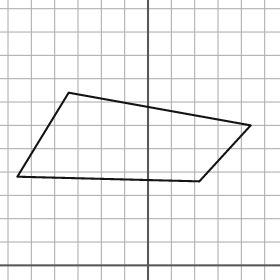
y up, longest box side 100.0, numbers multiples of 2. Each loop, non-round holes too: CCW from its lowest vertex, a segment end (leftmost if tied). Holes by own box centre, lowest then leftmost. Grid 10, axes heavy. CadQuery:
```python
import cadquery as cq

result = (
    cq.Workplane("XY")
    .moveTo(22.0, 36.0)
    .lineTo(44.0, 60.0)
    .lineTo(-34.0, 74.0)
    .lineTo(-56.0, 38.0)
    .close()
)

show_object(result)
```